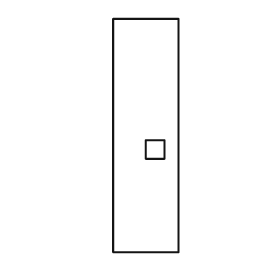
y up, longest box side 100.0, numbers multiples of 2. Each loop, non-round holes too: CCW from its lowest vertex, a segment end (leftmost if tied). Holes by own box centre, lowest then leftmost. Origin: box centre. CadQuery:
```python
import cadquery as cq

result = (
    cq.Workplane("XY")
    .moveTo(-14.0, -50.0)
    .lineTo(14.0, -50.0)
    .lineTo(14.0, 50.0)
    .lineTo(-14.0, 50.0)
    .close()
    .moveTo(0.0, -10.0)
    .lineTo(8.0, -10.0)
    .lineTo(8.0, -2.0)
    .lineTo(0.0, -2.0)
    .close()
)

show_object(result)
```